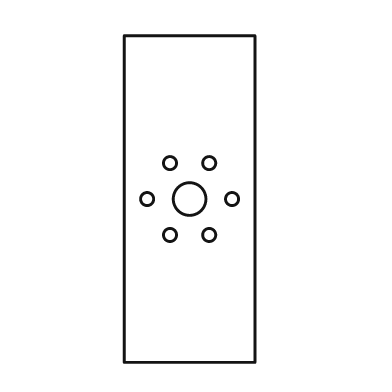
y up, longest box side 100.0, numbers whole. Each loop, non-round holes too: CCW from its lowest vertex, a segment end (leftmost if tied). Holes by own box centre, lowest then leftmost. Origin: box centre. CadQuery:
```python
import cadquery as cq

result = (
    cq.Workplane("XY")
    .moveTo(-20.0, -50.0)
    .lineTo(20.0, -50.0)
    .lineTo(20.0, 50.0)
    .lineTo(-20.0, 50.0)
    .close()
    .moveTo(-6.0, -11.0)
    .circle(2.0)
    .moveTo(6.0, -11.0)
    .circle(2.0)
    .moveTo(-13.0, 0.0)
    .circle(2.0)
    .moveTo(0.0, 0.0)
    .circle(5.0)
    .moveTo(13.0, 0.0)
    .circle(2.0)
    .moveTo(-6.0, 11.0)
    .circle(2.0)
    .moveTo(6.0, 11.0)
    .circle(2.0)
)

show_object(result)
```